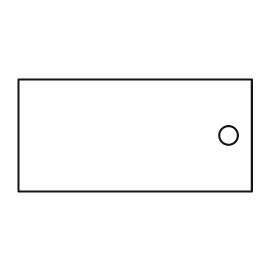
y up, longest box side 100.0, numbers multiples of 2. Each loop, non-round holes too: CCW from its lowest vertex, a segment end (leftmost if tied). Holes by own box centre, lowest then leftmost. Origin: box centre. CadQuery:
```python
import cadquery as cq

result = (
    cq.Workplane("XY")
    .moveTo(-50.0, -24.0)
    .lineTo(50.0, -24.0)
    .lineTo(50.0, 24.0)
    .lineTo(-50.0, 24.0)
    .close()
    .moveTo(40.0, 0.0)
    .circle(4.0)
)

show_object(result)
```